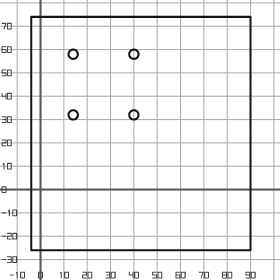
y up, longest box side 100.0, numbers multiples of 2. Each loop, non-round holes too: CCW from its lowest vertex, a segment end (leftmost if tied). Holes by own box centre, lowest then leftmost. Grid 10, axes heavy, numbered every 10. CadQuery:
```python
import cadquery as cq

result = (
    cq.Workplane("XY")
    .moveTo(-4.0, -26.0)
    .lineTo(90.0, -26.0)
    .lineTo(90.0, 74.0)
    .lineTo(-4.0, 74.0)
    .close()
    .moveTo(14.0, 32.0)
    .circle(2.0)
    .moveTo(40.0, 32.0)
    .circle(2.0)
    .moveTo(14.0, 58.0)
    .circle(2.0)
    .moveTo(40.0, 58.0)
    .circle(2.0)
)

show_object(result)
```